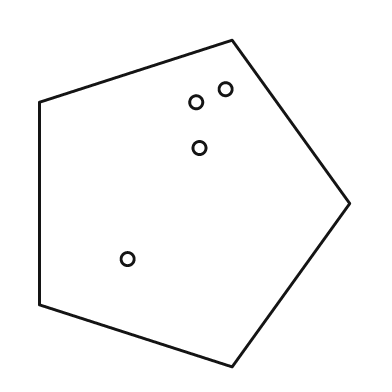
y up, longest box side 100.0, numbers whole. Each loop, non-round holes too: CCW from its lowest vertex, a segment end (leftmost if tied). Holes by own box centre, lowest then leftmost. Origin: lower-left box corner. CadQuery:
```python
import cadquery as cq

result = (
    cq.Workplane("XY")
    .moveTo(59.0, 0.0)
    .lineTo(95.0, 50.0)
    .lineTo(59.0, 100.0)
    .lineTo(0.0, 81.0)
    .lineTo(0.0, 19.0)
    .close()
    .moveTo(27.0, 33.0)
    .circle(2.0)
    .moveTo(49.0, 67.0)
    .circle(2.0)
    .moveTo(48.0, 81.0)
    .circle(2.0)
    .moveTo(57.0, 85.0)
    .circle(2.0)
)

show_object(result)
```